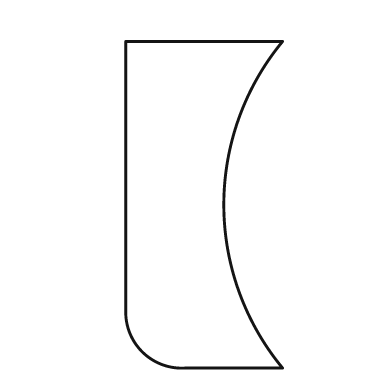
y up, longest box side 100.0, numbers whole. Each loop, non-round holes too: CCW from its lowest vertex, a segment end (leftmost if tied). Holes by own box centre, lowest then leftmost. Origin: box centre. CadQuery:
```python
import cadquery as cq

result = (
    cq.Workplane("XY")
    .moveTo(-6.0, -50.0)
    .lineTo(24.0, -50.0)
    .threePointArc((6.0, 0.0), (24.0, 50.0))
    .lineTo(-24.0, 50.0)
    .lineTo(-24.0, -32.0)
    .threePointArc((-19.0, -45.0), (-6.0, -50.0))
    .close()
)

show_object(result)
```